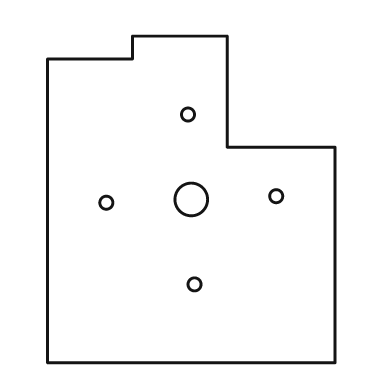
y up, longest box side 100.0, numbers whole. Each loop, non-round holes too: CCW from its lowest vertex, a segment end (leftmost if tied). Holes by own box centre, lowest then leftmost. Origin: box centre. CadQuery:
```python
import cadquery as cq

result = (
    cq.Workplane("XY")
    .moveTo(-44.0, -50.0)
    .lineTo(44.0, -50.0)
    .lineTo(44.0, 16.0)
    .lineTo(11.0, 16.0)
    .lineTo(11.0, 50.0)
    .lineTo(-18.0, 50.0)
    .lineTo(-18.0, 43.0)
    .lineTo(-44.0, 43.0)
    .close()
    .moveTo(1.0, -26.0)
    .circle(2.0)
    .moveTo(-26.0, -1.0)
    .circle(2.0)
    .moveTo(0.0, 0.0)
    .circle(5.0)
    .moveTo(26.0, 1.0)
    .circle(2.0)
    .moveTo(-1.0, 26.0)
    .circle(2.0)
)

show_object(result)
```